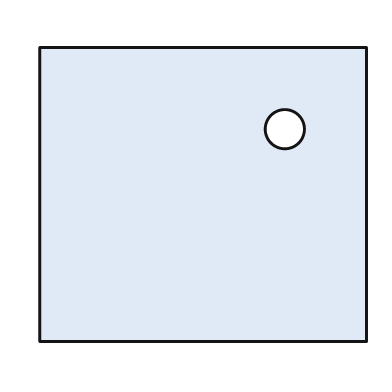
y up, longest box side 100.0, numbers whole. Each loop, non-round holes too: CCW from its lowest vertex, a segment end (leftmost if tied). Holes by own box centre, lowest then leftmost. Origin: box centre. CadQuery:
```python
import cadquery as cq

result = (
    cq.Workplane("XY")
    .moveTo(-50.0, -45.0)
    .lineTo(50.0, -45.0)
    .lineTo(50.0, 45.0)
    .lineTo(-50.0, 45.0)
    .close()
    .moveTo(25.0, 20.0)
    .circle(6.0)
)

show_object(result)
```